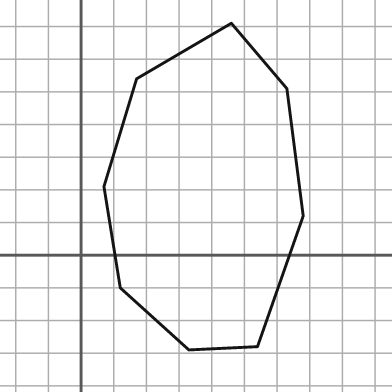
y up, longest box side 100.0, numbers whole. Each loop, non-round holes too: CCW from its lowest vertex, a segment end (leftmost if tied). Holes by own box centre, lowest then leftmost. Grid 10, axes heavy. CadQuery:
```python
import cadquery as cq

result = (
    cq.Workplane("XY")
    .moveTo(33.0, -29.0)
    .lineTo(54.0, -28.0)
    .lineTo(68.0, 12.0)
    .lineTo(63.0, 51.0)
    .lineTo(46.0, 71.0)
    .lineTo(17.0, 54.0)
    .lineTo(7.0, 21.0)
    .lineTo(12.0, -10.0)
    .close()
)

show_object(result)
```